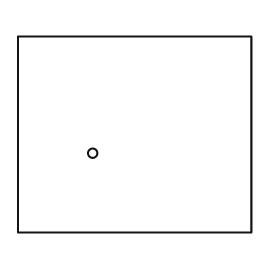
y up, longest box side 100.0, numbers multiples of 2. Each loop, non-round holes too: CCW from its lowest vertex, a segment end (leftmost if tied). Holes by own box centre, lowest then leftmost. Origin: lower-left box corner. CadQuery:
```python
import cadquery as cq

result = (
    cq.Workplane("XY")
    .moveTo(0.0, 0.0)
    .lineTo(100.0, 0.0)
    .lineTo(100.0, 84.0)
    .lineTo(0.0, 84.0)
    .close()
    .moveTo(32.0, 34.0)
    .circle(2.0)
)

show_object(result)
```